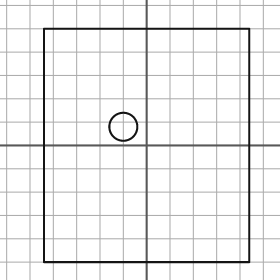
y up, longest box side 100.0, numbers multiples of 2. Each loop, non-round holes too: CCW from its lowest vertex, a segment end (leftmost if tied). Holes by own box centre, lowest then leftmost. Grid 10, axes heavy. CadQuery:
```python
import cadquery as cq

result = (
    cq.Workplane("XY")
    .moveTo(-44.0, -50.0)
    .lineTo(44.0, -50.0)
    .lineTo(44.0, 50.0)
    .lineTo(-44.0, 50.0)
    .close()
    .moveTo(-10.0, 8.0)
    .circle(6.0)
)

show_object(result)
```